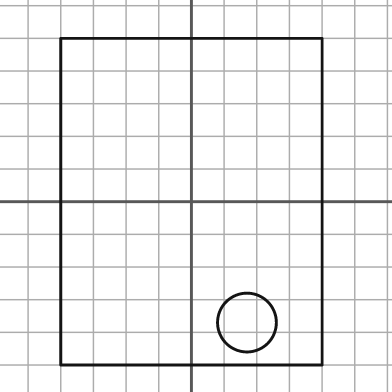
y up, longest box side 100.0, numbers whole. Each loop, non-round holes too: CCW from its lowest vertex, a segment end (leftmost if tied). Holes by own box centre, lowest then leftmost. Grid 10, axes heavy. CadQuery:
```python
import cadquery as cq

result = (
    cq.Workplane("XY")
    .moveTo(-40.0, -50.0)
    .lineTo(40.0, -50.0)
    .lineTo(40.0, 50.0)
    .lineTo(-40.0, 50.0)
    .close()
    .moveTo(17.0, -37.0)
    .circle(9.0)
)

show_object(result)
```